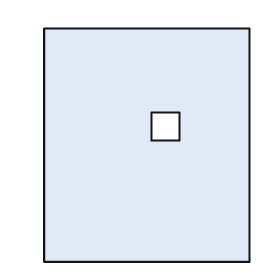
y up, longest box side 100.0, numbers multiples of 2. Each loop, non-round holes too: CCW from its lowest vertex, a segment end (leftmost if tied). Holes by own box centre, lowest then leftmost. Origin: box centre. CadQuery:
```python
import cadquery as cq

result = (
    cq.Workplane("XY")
    .moveTo(-44.0, -50.0)
    .lineTo(44.0, -50.0)
    .lineTo(44.0, 50.0)
    .lineTo(-44.0, 50.0)
    .close()
    .moveTo(2.0, 2.0)
    .lineTo(14.0, 2.0)
    .lineTo(14.0, 14.0)
    .lineTo(2.0, 14.0)
    .close()
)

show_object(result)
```